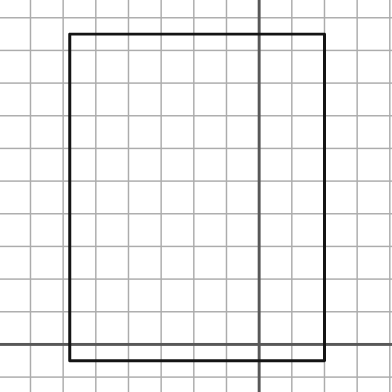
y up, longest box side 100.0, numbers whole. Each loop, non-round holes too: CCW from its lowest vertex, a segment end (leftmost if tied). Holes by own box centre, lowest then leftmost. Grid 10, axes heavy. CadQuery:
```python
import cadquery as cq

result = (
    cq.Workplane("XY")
    .moveTo(-58.0, -5.0)
    .lineTo(20.0, -5.0)
    .lineTo(20.0, 95.0)
    .lineTo(-58.0, 95.0)
    .close()
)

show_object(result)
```